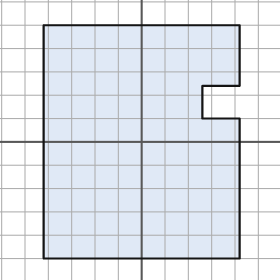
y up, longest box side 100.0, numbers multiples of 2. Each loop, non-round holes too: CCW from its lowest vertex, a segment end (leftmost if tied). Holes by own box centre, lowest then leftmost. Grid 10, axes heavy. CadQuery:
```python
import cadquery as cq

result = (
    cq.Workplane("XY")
    .moveTo(-42.0, -50.0)
    .lineTo(42.0, -50.0)
    .lineTo(42.0, 10.0)
    .lineTo(26.0, 10.0)
    .lineTo(26.0, 24.0)
    .lineTo(42.0, 24.0)
    .lineTo(42.0, 50.0)
    .lineTo(-42.0, 50.0)
    .close()
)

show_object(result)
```